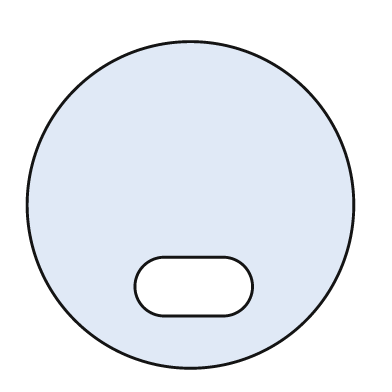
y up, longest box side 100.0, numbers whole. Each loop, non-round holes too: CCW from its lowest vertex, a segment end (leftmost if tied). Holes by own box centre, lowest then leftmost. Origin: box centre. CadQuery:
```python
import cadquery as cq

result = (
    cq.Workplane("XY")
    .moveTo(0.0, 0.0)
    .circle(50.0)
    .moveTo(-8.0, -34.0)
    .lineTo(10.0, -34.0)
    .threePointArc((19.0, -25.0), (10.0, -16.0))
    .lineTo(-8.0, -16.0)
    .threePointArc((-17.0, -25.0), (-8.0, -34.0))
    .close()
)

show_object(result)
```